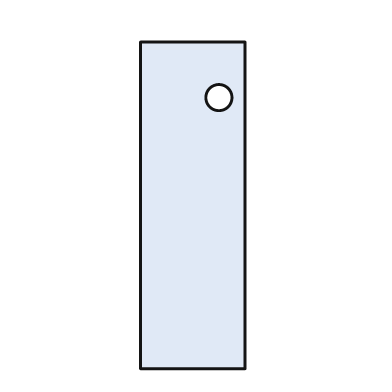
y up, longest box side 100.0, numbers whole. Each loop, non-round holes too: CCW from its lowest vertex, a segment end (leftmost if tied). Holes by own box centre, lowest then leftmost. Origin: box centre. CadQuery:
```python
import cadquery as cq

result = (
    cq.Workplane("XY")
    .moveTo(-16.0, -50.0)
    .lineTo(16.0, -50.0)
    .lineTo(16.0, 50.0)
    .lineTo(-16.0, 50.0)
    .close()
    .moveTo(8.0, 33.0)
    .circle(4.0)
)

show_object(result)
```